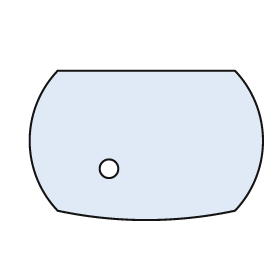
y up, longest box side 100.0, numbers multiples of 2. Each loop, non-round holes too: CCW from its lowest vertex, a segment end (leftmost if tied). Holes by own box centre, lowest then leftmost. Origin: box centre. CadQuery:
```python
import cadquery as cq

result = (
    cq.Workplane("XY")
    .moveTo(-38.0, -28.0)
    .threePointArc((0.0, -32.0), (38.0, -28.0))
    .threePointArc((50.0, 2.0), (38.0, 32.0))
    .lineTo(-38.0, 32.0)
    .threePointArc((-50.0, 2.0), (-38.0, -28.0))
    .close()
    .moveTo(-16.0, -10.0)
    .circle(4.0)
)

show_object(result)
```